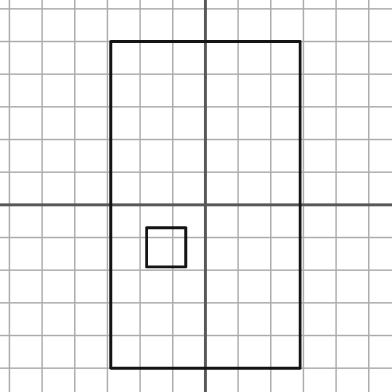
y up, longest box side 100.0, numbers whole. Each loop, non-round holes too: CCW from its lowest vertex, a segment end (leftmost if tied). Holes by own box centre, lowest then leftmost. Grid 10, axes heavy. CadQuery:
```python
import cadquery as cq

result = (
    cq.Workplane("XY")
    .moveTo(-29.0, -50.0)
    .lineTo(29.0, -50.0)
    .lineTo(29.0, 50.0)
    .lineTo(-29.0, 50.0)
    .close()
    .moveTo(-18.0, -19.0)
    .lineTo(-6.0, -19.0)
    .lineTo(-6.0, -7.0)
    .lineTo(-18.0, -7.0)
    .close()
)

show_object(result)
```